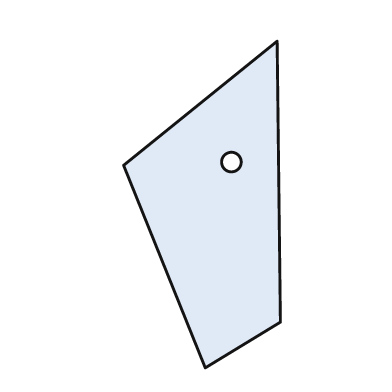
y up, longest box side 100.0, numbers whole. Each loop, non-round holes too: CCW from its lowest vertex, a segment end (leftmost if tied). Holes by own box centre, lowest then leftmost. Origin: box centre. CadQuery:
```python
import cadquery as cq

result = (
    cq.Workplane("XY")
    .moveTo(1.0, -50.0)
    .lineTo(24.0, -36.0)
    .lineTo(23.0, 50.0)
    .lineTo(-24.0, 12.0)
    .close()
    .moveTo(9.0, 13.0)
    .circle(3.0)
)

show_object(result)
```